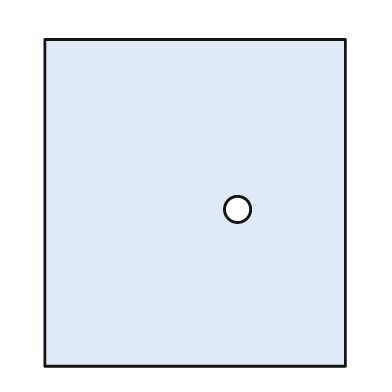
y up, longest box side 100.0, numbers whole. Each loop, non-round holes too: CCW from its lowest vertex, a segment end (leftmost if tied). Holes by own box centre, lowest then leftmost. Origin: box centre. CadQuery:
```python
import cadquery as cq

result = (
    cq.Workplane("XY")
    .moveTo(-46.0, -50.0)
    .lineTo(46.0, -50.0)
    .lineTo(46.0, 50.0)
    .lineTo(-46.0, 50.0)
    .close()
    .moveTo(13.0, -2.0)
    .circle(4.0)
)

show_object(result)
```